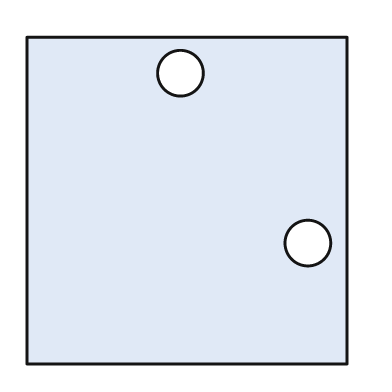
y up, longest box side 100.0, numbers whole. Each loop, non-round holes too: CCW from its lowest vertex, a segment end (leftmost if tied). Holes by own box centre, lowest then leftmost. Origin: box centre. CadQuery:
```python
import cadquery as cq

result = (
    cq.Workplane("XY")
    .moveTo(-49.0, -50.0)
    .lineTo(49.0, -50.0)
    .lineTo(49.0, 50.0)
    .lineTo(-49.0, 50.0)
    .close()
    .moveTo(37.0, -13.0)
    .circle(7.0)
    .moveTo(-2.0, 39.0)
    .circle(7.0)
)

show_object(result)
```